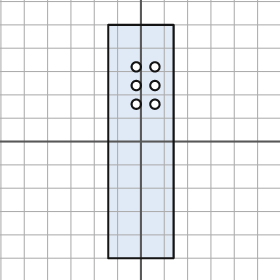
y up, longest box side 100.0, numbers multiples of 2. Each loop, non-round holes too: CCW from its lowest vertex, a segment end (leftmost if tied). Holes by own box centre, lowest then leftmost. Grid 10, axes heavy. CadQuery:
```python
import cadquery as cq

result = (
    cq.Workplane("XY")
    .moveTo(-14.0, -50.0)
    .lineTo(14.0, -50.0)
    .lineTo(14.0, 50.0)
    .lineTo(-14.0, 50.0)
    .close()
    .moveTo(-2.0, 16.0)
    .circle(2.0)
    .moveTo(6.0, 16.0)
    .circle(2.0)
    .moveTo(-2.0, 24.0)
    .circle(2.0)
    .moveTo(6.0, 24.0)
    .circle(2.0)
    .moveTo(-2.0, 32.0)
    .circle(2.0)
    .moveTo(6.0, 32.0)
    .circle(2.0)
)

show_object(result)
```